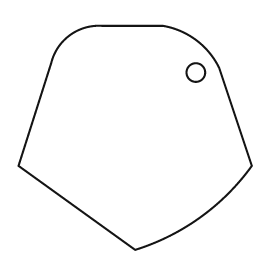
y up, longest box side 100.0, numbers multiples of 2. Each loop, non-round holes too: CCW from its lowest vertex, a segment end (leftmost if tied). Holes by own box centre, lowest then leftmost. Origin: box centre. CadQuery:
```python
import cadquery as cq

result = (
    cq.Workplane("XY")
    .moveTo(0.0, -48.0)
    .threePointArc((28.0, -34.0), (50.0, -12.0))
    .lineTo(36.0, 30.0)
    .threePointArc((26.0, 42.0), (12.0, 48.0))
    .lineTo(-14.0, 48.0)
    .threePointArc((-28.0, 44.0), (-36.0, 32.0))
    .lineTo(-50.0, -12.0)
    .close()
    .moveTo(26.0, 28.0)
    .circle(4.0)
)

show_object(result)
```